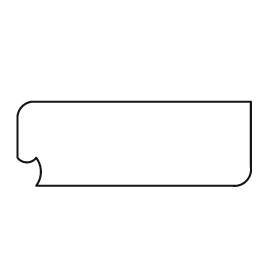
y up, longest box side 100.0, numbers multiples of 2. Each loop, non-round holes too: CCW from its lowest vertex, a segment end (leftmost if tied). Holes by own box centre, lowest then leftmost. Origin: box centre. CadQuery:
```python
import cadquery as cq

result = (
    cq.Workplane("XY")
    .moveTo(-42.0, -18.0)
    .lineTo(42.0, -18.0)
    .threePointArc((48.0, -16.0), (50.0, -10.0))
    .lineTo(50.0, 18.0)
    .lineTo(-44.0, 18.0)
    .threePointArc((-48.0, 16.0), (-50.0, 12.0))
    .lineTo(-50.0, -6.0)
    .threePointArc((-46.0, -8.0), (-42.0, -6.0))
    .threePointArc((-40.0, -12.0), (-42.0, -18.0))
    .close()
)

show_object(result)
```